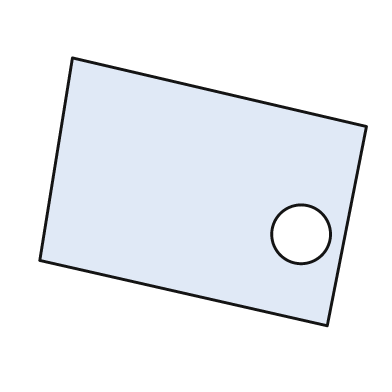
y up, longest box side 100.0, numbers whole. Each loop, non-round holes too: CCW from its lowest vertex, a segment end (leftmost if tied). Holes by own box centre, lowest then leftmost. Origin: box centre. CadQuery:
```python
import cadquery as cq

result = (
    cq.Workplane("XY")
    .moveTo(38.0, -41.0)
    .lineTo(50.0, 20.0)
    .lineTo(-40.0, 41.0)
    .lineTo(-50.0, -21.0)
    .close()
    .moveTo(30.0, -13.0)
    .circle(9.0)
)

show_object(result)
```